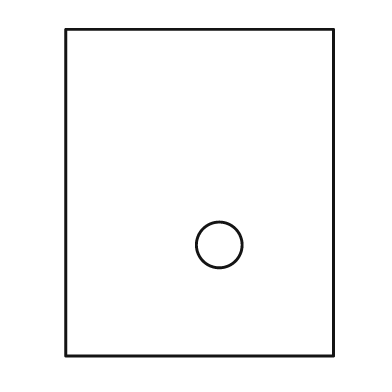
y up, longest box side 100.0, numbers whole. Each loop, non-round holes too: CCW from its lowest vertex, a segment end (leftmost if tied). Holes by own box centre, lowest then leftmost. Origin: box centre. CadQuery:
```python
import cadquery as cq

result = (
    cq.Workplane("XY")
    .moveTo(-41.0, -50.0)
    .lineTo(41.0, -50.0)
    .lineTo(41.0, 50.0)
    .lineTo(-41.0, 50.0)
    .close()
    .moveTo(6.0, -16.0)
    .circle(7.0)
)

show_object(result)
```